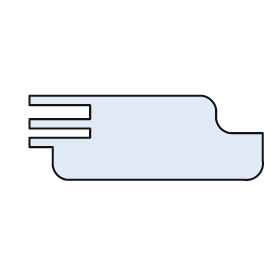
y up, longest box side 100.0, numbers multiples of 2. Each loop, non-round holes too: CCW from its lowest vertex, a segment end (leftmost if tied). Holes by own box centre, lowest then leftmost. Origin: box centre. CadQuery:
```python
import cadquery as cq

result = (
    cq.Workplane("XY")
    .moveTo(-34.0, -18.0)
    .lineTo(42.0, -18.0)
    .threePointArc((48.0, -16.0), (50.0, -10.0))
    .lineTo(50.0, 2.0)
    .lineTo(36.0, 2.0)
    .threePointArc((32.0, 4.0), (30.0, 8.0))
    .lineTo(30.0, 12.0)
    .threePointArc((28.0, 16.0), (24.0, 18.0))
    .lineTo(-50.0, 18.0)
    .lineTo(-50.0, 14.0)
    .lineTo(-24.0, 14.0)
    .lineTo(-24.0, 8.0)
    .lineTo(-50.0, 8.0)
    .lineTo(-50.0, 4.0)
    .lineTo(-24.0, 4.0)
    .lineTo(-24.0, 0.0)
    .lineTo(-50.0, 0.0)
    .lineTo(-50.0, -4.0)
    .lineTo(-40.0, -4.0)
    .lineTo(-40.0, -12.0)
    .threePointArc((-38.0, -16.0), (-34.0, -18.0))
    .close()
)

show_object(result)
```